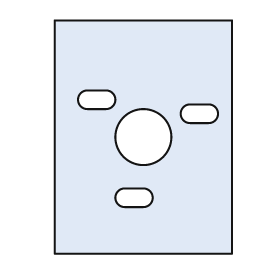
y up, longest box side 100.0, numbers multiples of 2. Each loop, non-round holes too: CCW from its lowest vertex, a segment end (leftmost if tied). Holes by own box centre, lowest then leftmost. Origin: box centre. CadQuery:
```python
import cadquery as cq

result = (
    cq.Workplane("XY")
    .moveTo(-38.0, -50.0)
    .lineTo(38.0, -50.0)
    .lineTo(38.0, 50.0)
    .lineTo(-38.0, 50.0)
    .close()
    .moveTo(-8.0, -30.0)
    .lineTo(0.0, -30.0)
    .threePointArc((4.0, -26.0), (0.0, -22.0))
    .lineTo(-8.0, -22.0)
    .threePointArc((-12.0, -26.0), (-8.0, -30.0))
    .close()
    .moveTo(0.0, 0.0)
    .circle(12.0)
    .moveTo(20.0, 6.0)
    .lineTo(28.0, 6.0)
    .threePointArc((32.0, 10.0), (28.0, 14.0))
    .lineTo(20.0, 14.0)
    .threePointArc((16.0, 10.0), (20.0, 6.0))
    .close()
    .moveTo(-24.0, 12.0)
    .lineTo(-16.0, 12.0)
    .threePointArc((-12.0, 16.0), (-16.0, 20.0))
    .lineTo(-24.0, 20.0)
    .threePointArc((-28.0, 16.0), (-24.0, 12.0))
    .close()
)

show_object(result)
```